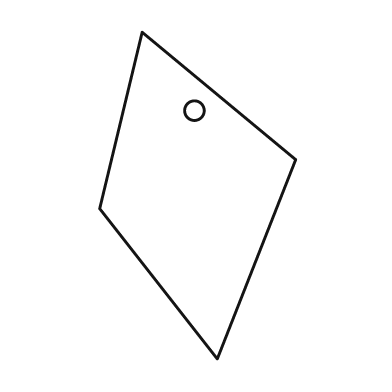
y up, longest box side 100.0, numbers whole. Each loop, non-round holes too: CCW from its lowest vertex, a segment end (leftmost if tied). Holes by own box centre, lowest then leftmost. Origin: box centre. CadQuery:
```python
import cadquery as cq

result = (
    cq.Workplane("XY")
    .moveTo(6.0, -50.0)
    .lineTo(30.0, 11.0)
    .lineTo(-17.0, 50.0)
    .lineTo(-30.0, -4.0)
    .close()
    .moveTo(-1.0, 26.0)
    .circle(3.0)
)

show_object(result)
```